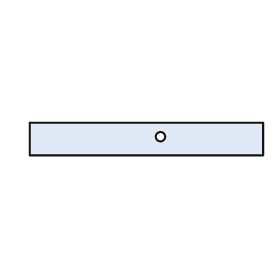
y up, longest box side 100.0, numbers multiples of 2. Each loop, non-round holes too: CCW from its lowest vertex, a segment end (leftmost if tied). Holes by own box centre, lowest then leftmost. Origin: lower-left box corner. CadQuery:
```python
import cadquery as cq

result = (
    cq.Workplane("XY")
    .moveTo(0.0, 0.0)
    .lineTo(100.0, 0.0)
    .lineTo(100.0, 14.0)
    .lineTo(0.0, 14.0)
    .close()
    .moveTo(56.0, 8.0)
    .circle(2.0)
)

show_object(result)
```